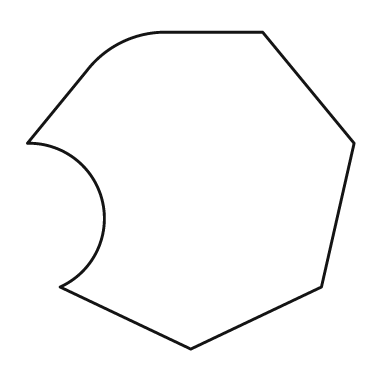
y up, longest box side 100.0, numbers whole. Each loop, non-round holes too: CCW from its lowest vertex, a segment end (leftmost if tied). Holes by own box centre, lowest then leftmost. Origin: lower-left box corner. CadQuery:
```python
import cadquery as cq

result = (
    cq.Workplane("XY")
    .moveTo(50.0, 0.0)
    .lineTo(90.0, 19.0)
    .lineTo(100.0, 63.0)
    .lineTo(72.0, 97.0)
    .lineTo(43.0, 97.0)
    .threePointArc((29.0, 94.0), (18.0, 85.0))
    .lineTo(0.0, 63.0)
    .threePointArc((23.0, 45.0), (10.0, 19.0))
    .close()
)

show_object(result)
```